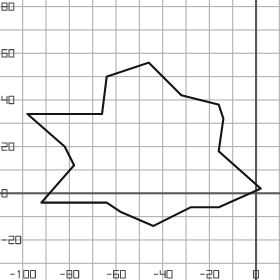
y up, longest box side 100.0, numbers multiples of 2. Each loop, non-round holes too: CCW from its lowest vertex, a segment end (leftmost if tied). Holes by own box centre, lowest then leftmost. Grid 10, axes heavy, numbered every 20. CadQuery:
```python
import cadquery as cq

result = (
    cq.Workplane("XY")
    .moveTo(-44.0, -14.0)
    .lineTo(-28.0, -6.0)
    .lineTo(-16.0, -6.0)
    .lineTo(2.0, 2.0)
    .lineTo(-16.0, 18.0)
    .lineTo(-14.0, 32.0)
    .lineTo(-16.0, 38.0)
    .lineTo(-32.0, 42.0)
    .lineTo(-46.0, 56.0)
    .lineTo(-64.0, 50.0)
    .lineTo(-66.0, 34.0)
    .lineTo(-98.0, 34.0)
    .lineTo(-82.0, 20.0)
    .lineTo(-78.0, 12.0)
    .lineTo(-92.0, -4.0)
    .lineTo(-64.0, -4.0)
    .lineTo(-58.0, -8.0)
    .close()
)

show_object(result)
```